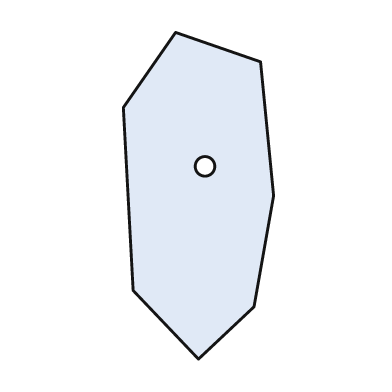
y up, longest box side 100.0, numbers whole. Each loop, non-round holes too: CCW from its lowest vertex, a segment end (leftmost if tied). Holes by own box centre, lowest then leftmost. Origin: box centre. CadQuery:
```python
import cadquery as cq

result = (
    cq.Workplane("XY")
    .moveTo(0.0, -50.0)
    .lineTo(17.0, -34.0)
    .lineTo(23.0, 0.0)
    .lineTo(19.0, 41.0)
    .lineTo(-7.0, 50.0)
    .lineTo(-23.0, 27.0)
    .lineTo(-20.0, -29.0)
    .close()
    .moveTo(2.0, 9.0)
    .circle(3.0)
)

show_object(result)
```